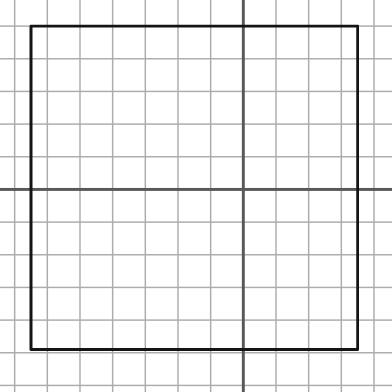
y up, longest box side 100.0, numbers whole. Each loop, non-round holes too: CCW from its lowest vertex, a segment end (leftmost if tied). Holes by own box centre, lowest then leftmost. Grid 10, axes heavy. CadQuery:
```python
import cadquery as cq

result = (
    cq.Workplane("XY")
    .moveTo(-65.0, -49.0)
    .lineTo(35.0, -49.0)
    .lineTo(35.0, 50.0)
    .lineTo(-65.0, 50.0)
    .close()
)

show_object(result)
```